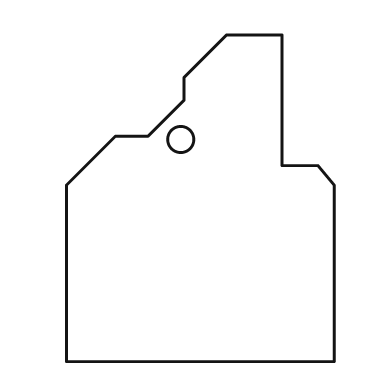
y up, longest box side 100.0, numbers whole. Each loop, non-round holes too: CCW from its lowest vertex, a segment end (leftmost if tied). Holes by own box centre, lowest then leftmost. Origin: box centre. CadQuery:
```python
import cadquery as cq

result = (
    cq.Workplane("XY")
    .moveTo(-41.0, -50.0)
    .lineTo(41.0, -50.0)
    .lineTo(41.0, 4.0)
    .lineTo(36.0, 10.0)
    .lineTo(25.0, 10.0)
    .lineTo(25.0, 50.0)
    .lineTo(8.0, 50.0)
    .lineTo(-5.0, 37.0)
    .lineTo(-5.0, 30.0)
    .lineTo(-16.0, 19.0)
    .lineTo(-26.0, 19.0)
    .lineTo(-41.0, 4.0)
    .close()
    .moveTo(-6.0, 18.0)
    .circle(4.0)
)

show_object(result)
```